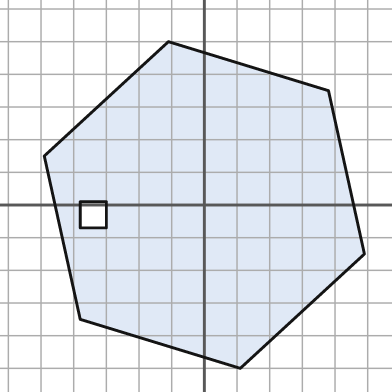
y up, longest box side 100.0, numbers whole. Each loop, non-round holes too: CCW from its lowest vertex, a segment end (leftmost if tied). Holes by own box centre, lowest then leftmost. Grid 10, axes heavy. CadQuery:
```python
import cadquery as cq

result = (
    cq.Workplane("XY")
    .moveTo(11.0, -50.0)
    .lineTo(49.0, -15.0)
    .lineTo(38.0, 35.0)
    .lineTo(-11.0, 50.0)
    .lineTo(-49.0, 15.0)
    .lineTo(-38.0, -35.0)
    .close()
    .moveTo(-38.0, -7.0)
    .lineTo(-30.0, -7.0)
    .lineTo(-30.0, 1.0)
    .lineTo(-38.0, 1.0)
    .close()
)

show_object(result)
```